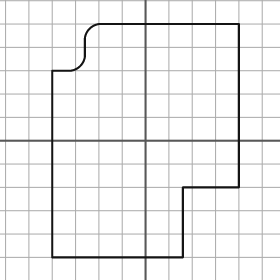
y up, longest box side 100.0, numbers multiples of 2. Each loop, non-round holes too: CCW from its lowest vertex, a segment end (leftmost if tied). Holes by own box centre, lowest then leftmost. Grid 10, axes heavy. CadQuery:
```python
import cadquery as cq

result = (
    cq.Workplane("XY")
    .moveTo(-40.0, -50.0)
    .lineTo(16.0, -50.0)
    .lineTo(16.0, -20.0)
    .lineTo(40.0, -20.0)
    .lineTo(40.0, 50.0)
    .lineTo(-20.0, 50.0)
    .threePointArc((-24.0, 48.0), (-26.0, 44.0))
    .lineTo(-26.0, 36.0)
    .threePointArc((-28.0, 32.0), (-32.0, 30.0))
    .lineTo(-40.0, 30.0)
    .close()
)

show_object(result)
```